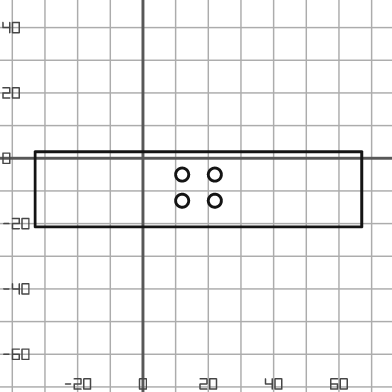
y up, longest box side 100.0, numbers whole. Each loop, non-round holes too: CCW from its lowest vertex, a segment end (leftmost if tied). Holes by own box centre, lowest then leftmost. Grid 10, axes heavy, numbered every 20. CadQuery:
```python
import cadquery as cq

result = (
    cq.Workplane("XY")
    .moveTo(-33.0, -21.0)
    .lineTo(67.0, -21.0)
    .lineTo(67.0, 2.0)
    .lineTo(-33.0, 2.0)
    .close()
    .moveTo(12.0, -13.0)
    .circle(2.0)
    .moveTo(22.0, -13.0)
    .circle(2.0)
    .moveTo(12.0, -5.0)
    .circle(2.0)
    .moveTo(22.0, -5.0)
    .circle(2.0)
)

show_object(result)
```